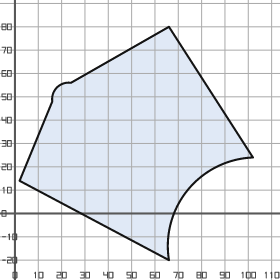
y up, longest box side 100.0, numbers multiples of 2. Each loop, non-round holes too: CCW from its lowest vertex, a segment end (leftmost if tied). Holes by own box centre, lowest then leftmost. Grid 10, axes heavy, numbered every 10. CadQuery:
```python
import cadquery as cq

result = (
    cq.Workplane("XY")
    .moveTo(66.0, -20.0)
    .threePointArc((74.0, 10.0), (102.0, 24.0))
    .lineTo(66.0, 80.0)
    .lineTo(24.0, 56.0)
    .threePointArc((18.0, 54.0), (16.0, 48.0))
    .lineTo(2.0, 14.0)
    .close()
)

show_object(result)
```